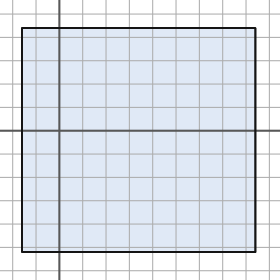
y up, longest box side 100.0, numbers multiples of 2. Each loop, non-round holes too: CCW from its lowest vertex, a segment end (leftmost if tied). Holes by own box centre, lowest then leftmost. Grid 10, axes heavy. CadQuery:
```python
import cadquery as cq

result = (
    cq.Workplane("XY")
    .moveTo(-16.0, -52.0)
    .lineTo(84.0, -52.0)
    .lineTo(84.0, 44.0)
    .lineTo(-16.0, 44.0)
    .close()
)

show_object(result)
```